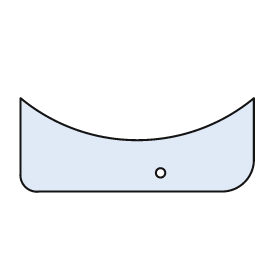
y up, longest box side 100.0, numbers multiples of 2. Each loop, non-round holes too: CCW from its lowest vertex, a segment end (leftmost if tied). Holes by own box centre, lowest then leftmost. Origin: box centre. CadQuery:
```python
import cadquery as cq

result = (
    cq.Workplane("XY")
    .moveTo(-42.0, -20.0)
    .lineTo(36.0, -20.0)
    .threePointArc((46.0, -16.0), (50.0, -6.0))
    .lineTo(50.0, 20.0)
    .threePointArc((0.0, 2.0), (-50.0, 20.0))
    .lineTo(-50.0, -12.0)
    .threePointArc((-48.0, -18.0), (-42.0, -20.0))
    .close()
    .moveTo(10.0, -12.0)
    .circle(2.0)
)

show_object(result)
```